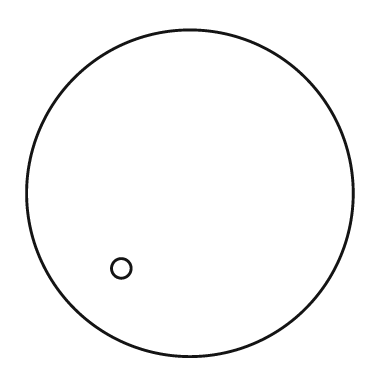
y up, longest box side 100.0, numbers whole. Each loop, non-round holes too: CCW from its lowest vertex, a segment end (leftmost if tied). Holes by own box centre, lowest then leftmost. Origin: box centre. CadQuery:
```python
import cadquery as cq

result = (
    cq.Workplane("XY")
    .moveTo(0.0, 0.0)
    .circle(50.0)
    .moveTo(-21.0, -23.0)
    .circle(3.0)
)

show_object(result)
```